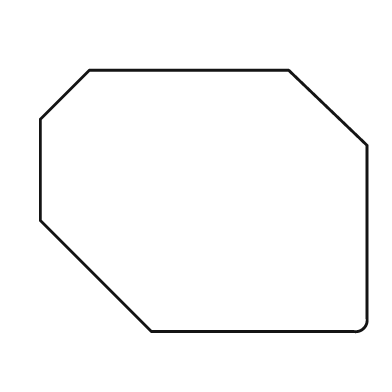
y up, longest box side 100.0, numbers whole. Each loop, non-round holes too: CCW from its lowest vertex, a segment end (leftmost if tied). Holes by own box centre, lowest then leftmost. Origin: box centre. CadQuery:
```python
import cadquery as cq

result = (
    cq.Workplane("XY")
    .moveTo(-16.0, -40.0)
    .lineTo(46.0, -40.0)
    .threePointArc((49.0, -39.0), (50.0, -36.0))
    .lineTo(50.0, 17.0)
    .lineTo(26.0, 40.0)
    .lineTo(-35.0, 40.0)
    .lineTo(-50.0, 25.0)
    .lineTo(-50.0, -6.0)
    .close()
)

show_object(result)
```